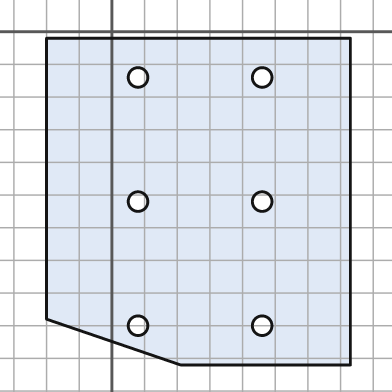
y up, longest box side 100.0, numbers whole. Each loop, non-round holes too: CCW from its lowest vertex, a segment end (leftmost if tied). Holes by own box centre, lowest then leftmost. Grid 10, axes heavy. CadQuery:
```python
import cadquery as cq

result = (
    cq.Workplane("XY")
    .moveTo(21.0, -102.0)
    .lineTo(73.0, -102.0)
    .lineTo(73.0, -2.0)
    .lineTo(-20.0, -2.0)
    .lineTo(-20.0, -88.0)
    .close()
    .moveTo(8.0, -90.0)
    .circle(3.0)
    .moveTo(46.0, -90.0)
    .circle(3.0)
    .moveTo(8.0, -52.0)
    .circle(3.0)
    .moveTo(46.0, -52.0)
    .circle(3.0)
    .moveTo(8.0, -14.0)
    .circle(3.0)
    .moveTo(46.0, -14.0)
    .circle(3.0)
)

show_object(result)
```